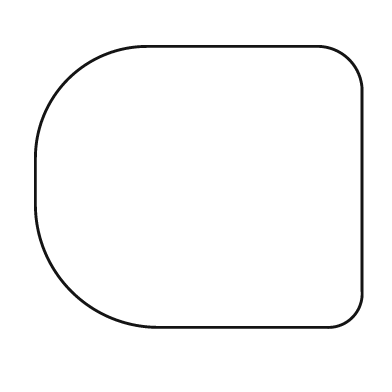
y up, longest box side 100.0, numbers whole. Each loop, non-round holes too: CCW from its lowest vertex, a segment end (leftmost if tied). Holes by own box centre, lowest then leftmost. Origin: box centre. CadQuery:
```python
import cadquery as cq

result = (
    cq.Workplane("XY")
    .moveTo(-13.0, -43.0)
    .lineTo(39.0, -43.0)
    .threePointArc((47.0, -40.0), (50.0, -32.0))
    .lineTo(50.0, 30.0)
    .threePointArc((46.0, 39.0), (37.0, 43.0))
    .lineTo(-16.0, 43.0)
    .threePointArc((-40.0, 33.0), (-50.0, 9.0))
    .lineTo(-50.0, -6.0)
    .threePointArc((-39.0, -32.0), (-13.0, -43.0))
    .close()
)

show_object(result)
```